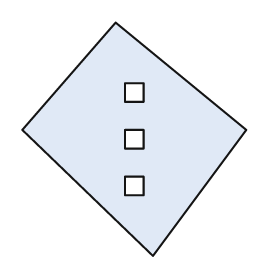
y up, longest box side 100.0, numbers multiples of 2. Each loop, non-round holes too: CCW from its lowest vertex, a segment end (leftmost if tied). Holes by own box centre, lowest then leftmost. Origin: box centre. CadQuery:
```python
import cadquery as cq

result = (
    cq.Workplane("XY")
    .moveTo(8.0, -50.0)
    .lineTo(48.0, 4.0)
    .lineTo(-8.0, 50.0)
    .lineTo(-48.0, 4.0)
    .close()
    .moveTo(-4.0, -24.0)
    .lineTo(4.0, -24.0)
    .lineTo(4.0, -16.0)
    .lineTo(-4.0, -16.0)
    .close()
    .moveTo(-4.0, -4.0)
    .lineTo(4.0, -4.0)
    .lineTo(4.0, 4.0)
    .lineTo(-4.0, 4.0)
    .close()
    .moveTo(-4.0, 16.0)
    .lineTo(4.0, 16.0)
    .lineTo(4.0, 24.0)
    .lineTo(-4.0, 24.0)
    .close()
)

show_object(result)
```